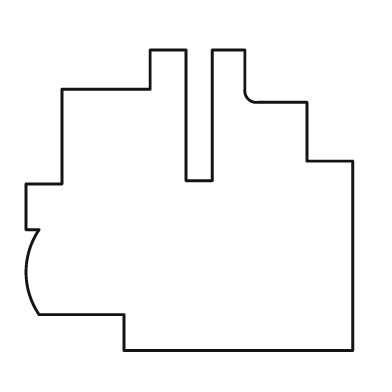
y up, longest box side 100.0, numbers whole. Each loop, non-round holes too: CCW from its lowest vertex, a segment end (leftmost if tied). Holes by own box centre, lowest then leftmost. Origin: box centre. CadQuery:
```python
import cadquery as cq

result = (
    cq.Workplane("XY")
    .moveTo(-20.0, -46.0)
    .lineTo(50.0, -46.0)
    .lineTo(50.0, 12.0)
    .lineTo(36.0, 12.0)
    .lineTo(36.0, 30.0)
    .lineTo(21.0, 30.0)
    .threePointArc((18.0, 31.0), (17.0, 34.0))
    .lineTo(17.0, 46.0)
    .lineTo(7.0, 46.0)
    .lineTo(7.0, 6.0)
    .lineTo(-1.0, 6.0)
    .lineTo(-1.0, 46.0)
    .lineTo(-12.0, 46.0)
    .lineTo(-12.0, 34.0)
    .lineTo(-39.0, 34.0)
    .lineTo(-39.0, 5.0)
    .lineTo(-50.0, 5.0)
    .lineTo(-50.0, -9.0)
    .lineTo(-46.0, -9.0)
    .threePointArc((-50.0, -22.0), (-46.0, -35.0))
    .lineTo(-20.0, -35.0)
    .close()
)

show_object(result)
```